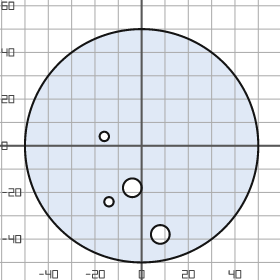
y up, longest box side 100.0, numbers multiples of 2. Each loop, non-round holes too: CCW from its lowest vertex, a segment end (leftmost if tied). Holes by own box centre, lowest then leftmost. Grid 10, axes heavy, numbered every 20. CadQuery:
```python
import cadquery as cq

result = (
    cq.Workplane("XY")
    .moveTo(0.0, 0.0)
    .circle(50.0)
    .moveTo(8.0, -38.0)
    .circle(4.0)
    .moveTo(-14.0, -24.0)
    .circle(2.0)
    .moveTo(-4.0, -18.0)
    .circle(4.0)
    .moveTo(-16.0, 4.0)
    .circle(2.0)
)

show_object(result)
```